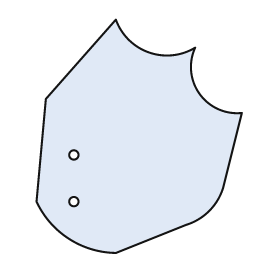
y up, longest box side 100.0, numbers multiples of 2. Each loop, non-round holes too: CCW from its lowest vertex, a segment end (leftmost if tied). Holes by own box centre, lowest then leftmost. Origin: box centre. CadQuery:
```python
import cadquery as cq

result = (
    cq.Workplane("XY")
    .moveTo(-10.0, -50.0)
    .lineTo(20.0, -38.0)
    .threePointArc((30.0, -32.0), (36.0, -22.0))
    .lineTo(44.0, 10.0)
    .threePointArc((26.0, 18.0), (24.0, 38.0))
    .threePointArc((4.0, 36.0), (-10.0, 50.0))
    .lineTo(-40.0, 16.0)
    .lineTo(-44.0, -28.0)
    .threePointArc((-30.0, -44.0), (-10.0, -50.0))
    .close()
    .moveTo(-28.0, -28.0)
    .circle(2.0)
    .moveTo(-28.0, -8.0)
    .circle(2.0)
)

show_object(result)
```